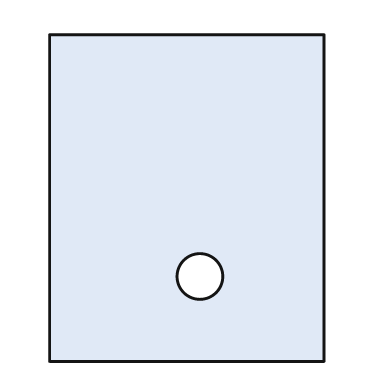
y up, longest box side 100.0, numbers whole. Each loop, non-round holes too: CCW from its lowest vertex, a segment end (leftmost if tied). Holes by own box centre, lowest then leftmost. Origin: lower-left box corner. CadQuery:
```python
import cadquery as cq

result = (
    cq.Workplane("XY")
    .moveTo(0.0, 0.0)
    .lineTo(84.0, 0.0)
    .lineTo(84.0, 100.0)
    .lineTo(0.0, 100.0)
    .close()
    .moveTo(46.0, 26.0)
    .circle(7.0)
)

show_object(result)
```